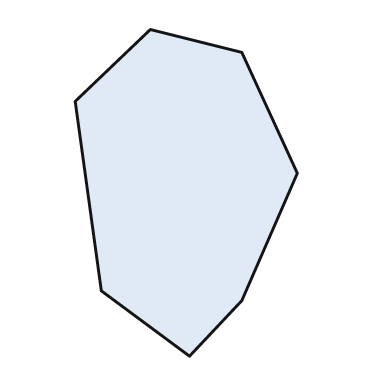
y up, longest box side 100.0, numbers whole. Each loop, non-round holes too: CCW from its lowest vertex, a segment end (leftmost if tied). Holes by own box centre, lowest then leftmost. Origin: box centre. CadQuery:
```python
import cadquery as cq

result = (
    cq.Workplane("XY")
    .moveTo(1.0, -50.0)
    .lineTo(17.0, -33.0)
    .lineTo(34.0, 6.0)
    .lineTo(17.0, 43.0)
    .lineTo(-11.0, 50.0)
    .lineTo(-34.0, 28.0)
    .lineTo(-26.0, -30.0)
    .close()
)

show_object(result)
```